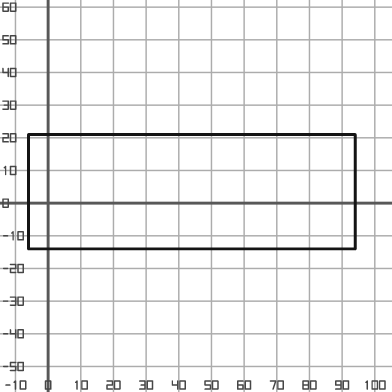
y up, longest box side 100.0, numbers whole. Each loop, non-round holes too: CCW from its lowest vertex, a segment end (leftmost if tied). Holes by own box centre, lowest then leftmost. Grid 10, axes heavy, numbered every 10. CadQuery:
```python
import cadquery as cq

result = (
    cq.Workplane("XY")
    .moveTo(-6.0, -14.0)
    .lineTo(94.0, -14.0)
    .lineTo(94.0, 21.0)
    .lineTo(-6.0, 21.0)
    .close()
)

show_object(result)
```